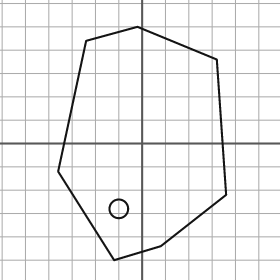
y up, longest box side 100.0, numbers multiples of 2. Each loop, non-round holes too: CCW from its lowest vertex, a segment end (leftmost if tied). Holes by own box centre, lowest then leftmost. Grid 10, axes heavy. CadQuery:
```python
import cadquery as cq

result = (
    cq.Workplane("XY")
    .moveTo(-12.0, -50.0)
    .lineTo(8.0, -44.0)
    .lineTo(36.0, -22.0)
    .lineTo(32.0, 36.0)
    .lineTo(-2.0, 50.0)
    .lineTo(-24.0, 44.0)
    .lineTo(-36.0, -12.0)
    .close()
    .moveTo(-10.0, -28.0)
    .circle(4.0)
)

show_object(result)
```